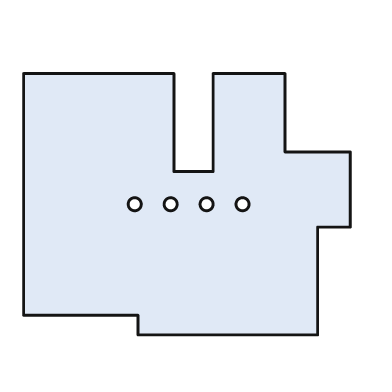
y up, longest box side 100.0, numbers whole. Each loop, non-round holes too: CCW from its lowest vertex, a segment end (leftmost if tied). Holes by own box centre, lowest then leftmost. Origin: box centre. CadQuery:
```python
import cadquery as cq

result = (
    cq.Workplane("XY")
    .moveTo(-15.0, -40.0)
    .lineTo(40.0, -40.0)
    .lineTo(40.0, -7.0)
    .lineTo(50.0, -7.0)
    .lineTo(50.0, 16.0)
    .lineTo(30.0, 16.0)
    .lineTo(30.0, 40.0)
    .lineTo(8.0, 40.0)
    .lineTo(8.0, 10.0)
    .lineTo(-4.0, 10.0)
    .lineTo(-4.0, 40.0)
    .lineTo(-50.0, 40.0)
    .lineTo(-50.0, -34.0)
    .lineTo(-15.0, -34.0)
    .close()
    .moveTo(-16.0, 0.0)
    .circle(2.0)
    .moveTo(-5.0, 0.0)
    .circle(2.0)
    .moveTo(6.0, 0.0)
    .circle(2.0)
    .moveTo(17.0, 0.0)
    .circle(2.0)
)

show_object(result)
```